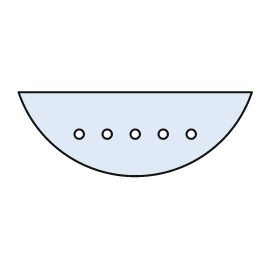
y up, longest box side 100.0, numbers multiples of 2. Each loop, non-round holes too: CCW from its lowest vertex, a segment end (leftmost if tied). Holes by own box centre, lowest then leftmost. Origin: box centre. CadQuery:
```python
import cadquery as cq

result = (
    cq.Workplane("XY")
    .moveTo(-50.0, 18.0)
    .threePointArc((0.0, -18.0), (50.0, 18.0))
    .close()
    .moveTo(-24.0, 0.0)
    .circle(2.0)
    .moveTo(-12.0, 0.0)
    .circle(2.0)
    .moveTo(0.0, 0.0)
    .circle(2.0)
    .moveTo(12.0, 0.0)
    .circle(2.0)
    .moveTo(24.0, 0.0)
    .circle(2.0)
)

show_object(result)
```